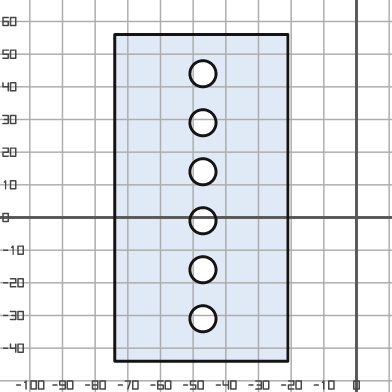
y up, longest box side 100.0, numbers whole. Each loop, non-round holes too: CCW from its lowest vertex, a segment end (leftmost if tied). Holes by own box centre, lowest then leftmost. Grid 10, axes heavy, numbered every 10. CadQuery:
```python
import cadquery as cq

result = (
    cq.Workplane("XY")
    .moveTo(-74.0, -44.0)
    .lineTo(-21.0, -44.0)
    .lineTo(-21.0, 56.0)
    .lineTo(-74.0, 56.0)
    .close()
    .moveTo(-47.0, -31.0)
    .circle(4.0)
    .moveTo(-47.0, -16.0)
    .circle(4.0)
    .moveTo(-47.0, -1.0)
    .circle(4.0)
    .moveTo(-47.0, 14.0)
    .circle(4.0)
    .moveTo(-47.0, 29.0)
    .circle(4.0)
    .moveTo(-47.0, 44.0)
    .circle(4.0)
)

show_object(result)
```